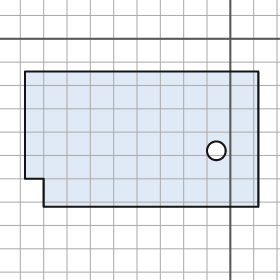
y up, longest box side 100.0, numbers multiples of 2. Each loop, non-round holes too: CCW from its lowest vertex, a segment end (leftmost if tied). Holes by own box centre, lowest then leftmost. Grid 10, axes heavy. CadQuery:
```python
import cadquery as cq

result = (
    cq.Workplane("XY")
    .moveTo(-80.0, -72.0)
    .lineTo(12.0, -72.0)
    .lineTo(12.0, -14.0)
    .lineTo(-88.0, -14.0)
    .lineTo(-88.0, -60.0)
    .lineTo(-80.0, -60.0)
    .close()
    .moveTo(-6.0, -48.0)
    .circle(4.0)
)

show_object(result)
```